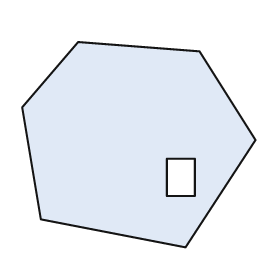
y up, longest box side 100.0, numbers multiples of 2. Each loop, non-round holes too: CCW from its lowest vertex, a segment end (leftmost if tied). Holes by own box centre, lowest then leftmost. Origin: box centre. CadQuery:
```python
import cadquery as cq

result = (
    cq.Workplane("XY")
    .moveTo(20.0, -44.0)
    .lineTo(50.0, 2.0)
    .lineTo(26.0, 40.0)
    .lineTo(-26.0, 44.0)
    .lineTo(-50.0, 16.0)
    .lineTo(-42.0, -32.0)
    .close()
    .moveTo(12.0, -22.0)
    .lineTo(24.0, -22.0)
    .lineTo(24.0, -6.0)
    .lineTo(12.0, -6.0)
    .close()
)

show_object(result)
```